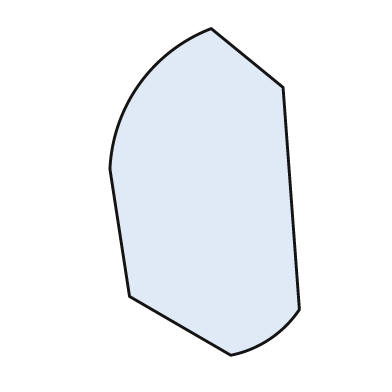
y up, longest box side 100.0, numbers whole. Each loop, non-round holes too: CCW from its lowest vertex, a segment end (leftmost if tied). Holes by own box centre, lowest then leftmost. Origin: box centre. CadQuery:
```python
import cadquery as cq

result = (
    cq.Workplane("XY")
    .moveTo(8.0, -50.0)
    .threePointArc((20.0, -45.0), (29.0, -36.0))
    .lineTo(24.0, 32.0)
    .lineTo(2.0, 50.0)
    .threePointArc((-20.0, 33.0), (-29.0, 7.0))
    .lineTo(-23.0, -32.0)
    .close()
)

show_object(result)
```